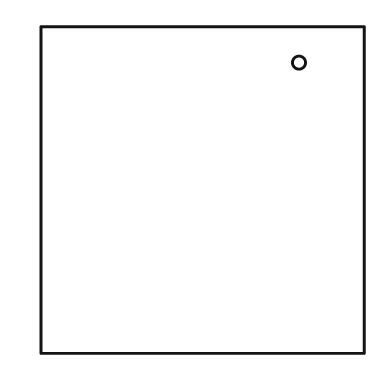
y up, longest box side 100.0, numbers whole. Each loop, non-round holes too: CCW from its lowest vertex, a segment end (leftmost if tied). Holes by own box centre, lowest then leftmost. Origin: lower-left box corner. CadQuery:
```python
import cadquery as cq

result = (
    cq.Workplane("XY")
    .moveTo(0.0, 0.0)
    .lineTo(99.0, 0.0)
    .lineTo(99.0, 100.0)
    .lineTo(0.0, 100.0)
    .close()
    .moveTo(79.0, 89.0)
    .circle(2.0)
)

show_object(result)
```